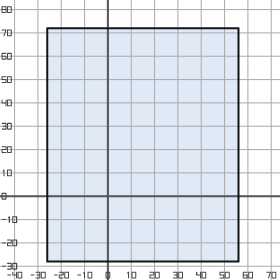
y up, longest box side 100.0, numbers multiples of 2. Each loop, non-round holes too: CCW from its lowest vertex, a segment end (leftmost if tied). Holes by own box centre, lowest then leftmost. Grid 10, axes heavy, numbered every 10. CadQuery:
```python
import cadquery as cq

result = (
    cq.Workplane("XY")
    .moveTo(-26.0, -28.0)
    .lineTo(56.0, -28.0)
    .lineTo(56.0, 72.0)
    .lineTo(-26.0, 72.0)
    .close()
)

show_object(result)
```